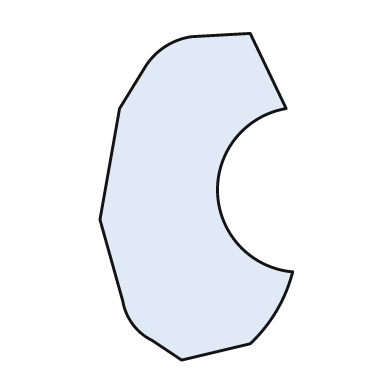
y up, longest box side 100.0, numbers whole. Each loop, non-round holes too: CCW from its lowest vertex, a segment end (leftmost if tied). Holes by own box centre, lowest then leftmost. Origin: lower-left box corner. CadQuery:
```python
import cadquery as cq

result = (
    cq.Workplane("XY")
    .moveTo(25.0, 0.0)
    .lineTo(46.0, 5.0)
    .threePointArc((54.0, 15.0), (59.0, 27.0))
    .threePointArc((36.0, 51.0), (57.0, 77.0))
    .lineTo(46.0, 100.0)
    .lineTo(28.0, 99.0)
    .threePointArc((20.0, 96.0), (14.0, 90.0))
    .lineTo(6.0, 77.0)
    .lineTo(0.0, 43.0)
    .lineTo(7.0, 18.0)
    .threePointArc((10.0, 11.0), (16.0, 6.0))
    .close()
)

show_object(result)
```